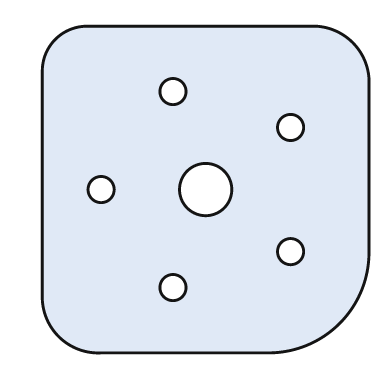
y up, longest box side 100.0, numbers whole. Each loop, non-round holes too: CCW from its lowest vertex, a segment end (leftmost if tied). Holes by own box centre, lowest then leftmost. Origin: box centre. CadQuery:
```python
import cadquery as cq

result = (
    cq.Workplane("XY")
    .moveTo(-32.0, -50.0)
    .lineTo(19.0, -50.0)
    .threePointArc((41.0, -41.0), (50.0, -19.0))
    .lineTo(50.0, 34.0)
    .threePointArc((45.0, 45.0), (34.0, 50.0))
    .lineTo(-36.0, 50.0)
    .threePointArc((-46.0, 46.0), (-50.0, 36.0))
    .lineTo(-50.0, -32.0)
    .threePointArc((-45.0, -45.0), (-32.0, -50.0))
    .close()
    .moveTo(-10.0, -30.0)
    .circle(4.0)
    .moveTo(26.0, -19.0)
    .circle(4.0)
    .moveTo(-32.0, 0.0)
    .circle(4.0)
    .moveTo(0.0, 0.0)
    .circle(8.0)
    .moveTo(26.0, 19.0)
    .circle(4.0)
    .moveTo(-10.0, 30.0)
    .circle(4.0)
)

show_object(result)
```